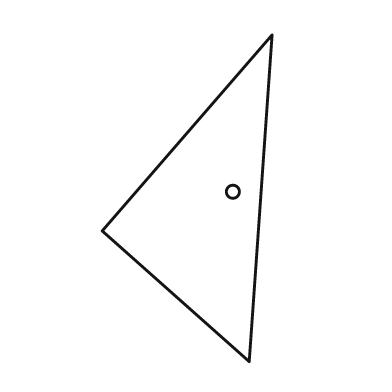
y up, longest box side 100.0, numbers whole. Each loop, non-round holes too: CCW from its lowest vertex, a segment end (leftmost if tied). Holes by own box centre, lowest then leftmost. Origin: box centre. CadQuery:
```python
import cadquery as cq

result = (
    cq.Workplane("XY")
    .moveTo(19.0, -50.0)
    .lineTo(26.0, 50.0)
    .lineTo(-26.0, -10.0)
    .close()
    .moveTo(14.0, 2.0)
    .circle(2.0)
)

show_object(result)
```